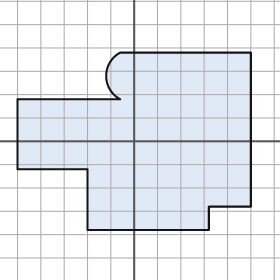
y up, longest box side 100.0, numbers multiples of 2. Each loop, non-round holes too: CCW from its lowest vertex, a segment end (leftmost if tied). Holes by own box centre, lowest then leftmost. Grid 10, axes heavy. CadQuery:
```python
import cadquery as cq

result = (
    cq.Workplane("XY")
    .moveTo(-20.0, -38.0)
    .lineTo(32.0, -38.0)
    .lineTo(32.0, -28.0)
    .lineTo(50.0, -28.0)
    .lineTo(50.0, 38.0)
    .lineTo(-6.0, 38.0)
    .threePointArc((-12.0, 28.0), (-6.0, 18.0))
    .lineTo(-50.0, 18.0)
    .lineTo(-50.0, -12.0)
    .lineTo(-20.0, -12.0)
    .close()
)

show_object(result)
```